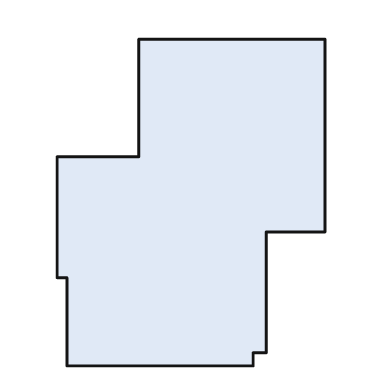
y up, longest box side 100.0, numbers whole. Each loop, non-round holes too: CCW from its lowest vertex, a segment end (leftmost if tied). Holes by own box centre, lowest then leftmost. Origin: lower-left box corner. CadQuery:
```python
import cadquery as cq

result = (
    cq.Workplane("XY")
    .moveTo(3.0, 0.0)
    .lineTo(60.0, 0.0)
    .lineTo(60.0, 4.0)
    .lineTo(64.0, 4.0)
    .lineTo(64.0, 41.0)
    .lineTo(82.0, 41.0)
    .lineTo(82.0, 100.0)
    .lineTo(25.0, 100.0)
    .lineTo(25.0, 64.0)
    .lineTo(0.0, 64.0)
    .lineTo(0.0, 27.0)
    .lineTo(3.0, 27.0)
    .close()
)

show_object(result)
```